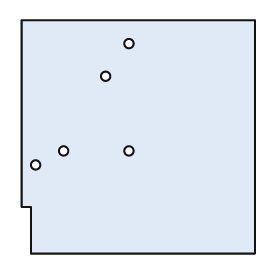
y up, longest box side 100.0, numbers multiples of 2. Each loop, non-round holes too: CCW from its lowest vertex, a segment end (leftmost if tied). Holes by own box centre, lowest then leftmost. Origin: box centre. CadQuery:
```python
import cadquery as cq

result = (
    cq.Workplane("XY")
    .moveTo(-46.0, -50.0)
    .lineTo(50.0, -50.0)
    .lineTo(50.0, 50.0)
    .lineTo(-50.0, 50.0)
    .lineTo(-50.0, -30.0)
    .lineTo(-46.0, -30.0)
    .close()
    .moveTo(-44.0, -12.0)
    .circle(2.0)
    .moveTo(-32.0, -6.0)
    .circle(2.0)
    .moveTo(-4.0, -6.0)
    .circle(2.0)
    .moveTo(-14.0, 26.0)
    .circle(2.0)
    .moveTo(-4.0, 40.0)
    .circle(2.0)
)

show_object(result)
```